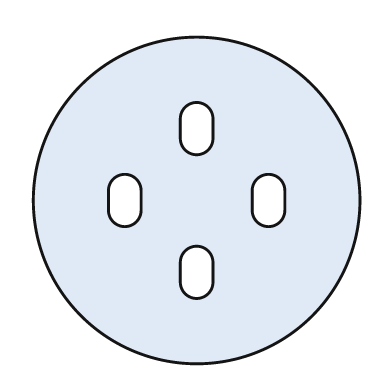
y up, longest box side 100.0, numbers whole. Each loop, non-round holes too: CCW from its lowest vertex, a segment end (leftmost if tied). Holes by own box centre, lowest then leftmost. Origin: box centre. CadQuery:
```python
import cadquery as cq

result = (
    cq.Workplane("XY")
    .moveTo(0.0, 0.0)
    .circle(50.0)
    .moveTo(-5.0, -25.0)
    .threePointArc((0.0, -30.0), (5.0, -25.0))
    .lineTo(5.0, -19.0)
    .threePointArc((0.0, -14.0), (-5.0, -19.0))
    .close()
    .moveTo(-27.0, -3.0)
    .threePointArc((-22.0, -8.0), (-17.0, -3.0))
    .lineTo(-17.0, 3.0)
    .threePointArc((-22.0, 8.0), (-27.0, 3.0))
    .close()
    .moveTo(17.0, -3.0)
    .threePointArc((22.0, -8.0), (27.0, -3.0))
    .lineTo(27.0, 3.0)
    .threePointArc((22.0, 8.0), (17.0, 3.0))
    .close()
    .moveTo(-5.0, 19.0)
    .threePointArc((0.0, 14.0), (5.0, 19.0))
    .lineTo(5.0, 25.0)
    .threePointArc((0.0, 30.0), (-5.0, 25.0))
    .close()
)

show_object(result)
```